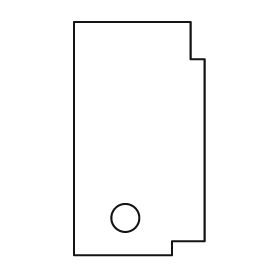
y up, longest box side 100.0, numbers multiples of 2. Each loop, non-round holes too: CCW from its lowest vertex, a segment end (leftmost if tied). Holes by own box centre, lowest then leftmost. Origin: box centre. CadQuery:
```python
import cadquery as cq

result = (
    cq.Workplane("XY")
    .moveTo(-28.0, -50.0)
    .lineTo(14.0, -50.0)
    .lineTo(14.0, -44.0)
    .lineTo(28.0, -44.0)
    .lineTo(28.0, 34.0)
    .lineTo(22.0, 34.0)
    .lineTo(22.0, 50.0)
    .lineTo(-28.0, 50.0)
    .close()
    .moveTo(-6.0, -34.0)
    .circle(6.0)
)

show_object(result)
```